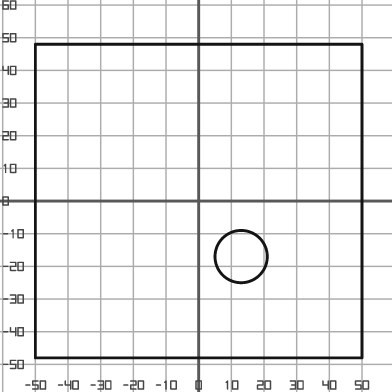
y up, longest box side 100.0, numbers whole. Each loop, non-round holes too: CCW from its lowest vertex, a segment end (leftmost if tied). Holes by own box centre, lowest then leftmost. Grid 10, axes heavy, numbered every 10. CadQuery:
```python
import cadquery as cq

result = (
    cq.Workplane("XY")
    .moveTo(-50.0, -48.0)
    .lineTo(50.0, -48.0)
    .lineTo(50.0, 48.0)
    .lineTo(-50.0, 48.0)
    .close()
    .moveTo(13.0, -17.0)
    .circle(8.0)
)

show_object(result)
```